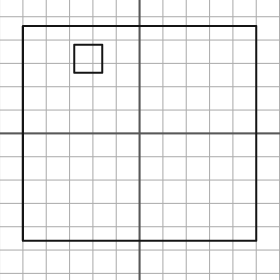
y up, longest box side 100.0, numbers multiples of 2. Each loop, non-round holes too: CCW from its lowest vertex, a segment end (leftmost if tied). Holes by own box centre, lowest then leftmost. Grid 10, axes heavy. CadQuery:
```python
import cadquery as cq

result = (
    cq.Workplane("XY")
    .moveTo(-50.0, -46.0)
    .lineTo(50.0, -46.0)
    .lineTo(50.0, 46.0)
    .lineTo(-50.0, 46.0)
    .close()
    .moveTo(-28.0, 26.0)
    .lineTo(-16.0, 26.0)
    .lineTo(-16.0, 38.0)
    .lineTo(-28.0, 38.0)
    .close()
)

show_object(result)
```